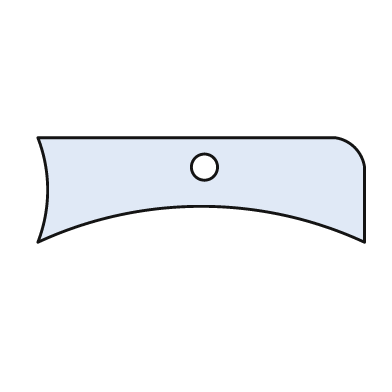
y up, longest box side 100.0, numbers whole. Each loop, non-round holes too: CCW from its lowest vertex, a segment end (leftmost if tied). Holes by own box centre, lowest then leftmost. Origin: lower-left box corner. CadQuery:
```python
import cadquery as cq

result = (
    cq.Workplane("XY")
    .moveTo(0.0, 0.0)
    .threePointArc((50.0, 11.0), (100.0, 0.0))
    .lineTo(100.0, 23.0)
    .threePointArc((97.0, 29.0), (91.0, 32.0))
    .lineTo(0.0, 32.0)
    .threePointArc((3.0, 16.0), (0.0, 0.0))
    .close()
    .moveTo(51.0, 23.0)
    .circle(4.0)
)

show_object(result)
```